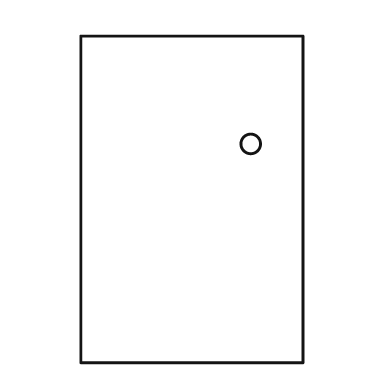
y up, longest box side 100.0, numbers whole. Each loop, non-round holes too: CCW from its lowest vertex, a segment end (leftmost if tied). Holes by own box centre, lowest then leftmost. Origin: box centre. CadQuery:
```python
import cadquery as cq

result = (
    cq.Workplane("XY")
    .moveTo(-34.0, -50.0)
    .lineTo(34.0, -50.0)
    .lineTo(34.0, 50.0)
    .lineTo(-34.0, 50.0)
    .close()
    .moveTo(18.0, 17.0)
    .circle(3.0)
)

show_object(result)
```